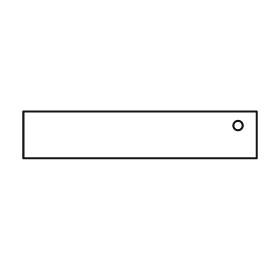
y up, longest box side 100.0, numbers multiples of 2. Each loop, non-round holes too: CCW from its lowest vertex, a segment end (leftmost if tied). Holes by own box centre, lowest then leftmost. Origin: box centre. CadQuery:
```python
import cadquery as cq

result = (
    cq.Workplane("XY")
    .moveTo(-50.0, -10.0)
    .lineTo(50.0, -10.0)
    .lineTo(50.0, 10.0)
    .lineTo(-50.0, 10.0)
    .close()
    .moveTo(42.0, 4.0)
    .circle(2.0)
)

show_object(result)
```